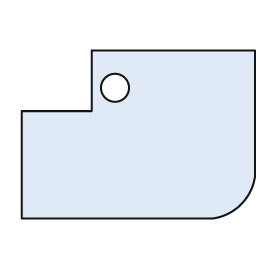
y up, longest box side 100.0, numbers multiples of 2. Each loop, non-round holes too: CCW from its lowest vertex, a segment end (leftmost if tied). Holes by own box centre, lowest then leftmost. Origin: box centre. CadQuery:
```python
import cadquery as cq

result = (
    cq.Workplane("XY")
    .moveTo(-50.0, -36.0)
    .lineTo(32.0, -36.0)
    .threePointArc((44.0, -30.0), (50.0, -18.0))
    .lineTo(50.0, 36.0)
    .lineTo(-20.0, 36.0)
    .lineTo(-20.0, 10.0)
    .lineTo(-50.0, 10.0)
    .close()
    .moveTo(-10.0, 20.0)
    .circle(6.0)
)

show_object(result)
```